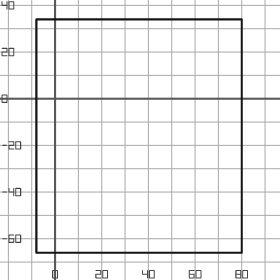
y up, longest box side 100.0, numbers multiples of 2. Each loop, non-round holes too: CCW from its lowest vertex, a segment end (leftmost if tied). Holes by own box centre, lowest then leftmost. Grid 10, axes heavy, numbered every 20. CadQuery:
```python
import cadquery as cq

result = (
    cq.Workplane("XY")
    .moveTo(-8.0, -66.0)
    .lineTo(80.0, -66.0)
    .lineTo(80.0, 34.0)
    .lineTo(-8.0, 34.0)
    .close()
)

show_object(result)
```